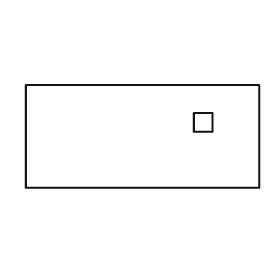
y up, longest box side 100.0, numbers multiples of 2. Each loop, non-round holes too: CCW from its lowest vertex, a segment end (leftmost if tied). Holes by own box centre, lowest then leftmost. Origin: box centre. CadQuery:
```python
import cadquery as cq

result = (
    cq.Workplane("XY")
    .moveTo(-50.0, -22.0)
    .lineTo(50.0, -22.0)
    .lineTo(50.0, 22.0)
    .lineTo(-50.0, 22.0)
    .close()
    .moveTo(22.0, 2.0)
    .lineTo(30.0, 2.0)
    .lineTo(30.0, 10.0)
    .lineTo(22.0, 10.0)
    .close()
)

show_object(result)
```